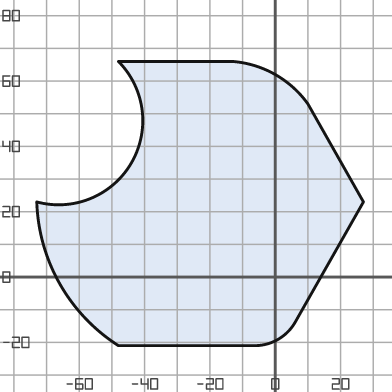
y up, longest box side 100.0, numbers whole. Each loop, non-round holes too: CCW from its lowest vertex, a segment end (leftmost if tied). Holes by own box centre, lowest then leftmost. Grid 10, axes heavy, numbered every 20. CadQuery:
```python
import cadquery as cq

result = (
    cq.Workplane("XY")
    .moveTo(-48.0, -21.0)
    .lineTo(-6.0, -21.0)
    .threePointArc((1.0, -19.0), (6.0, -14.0))
    .lineTo(27.0, 23.0)
    .lineTo(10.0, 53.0)
    .threePointArc((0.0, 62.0), (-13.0, 66.0))
    .lineTo(-48.0, 66.0)
    .threePointArc((-44.0, 35.0), (-73.0, 23.0))
    .threePointArc((-66.0, -2.0), (-48.0, -21.0))
    .close()
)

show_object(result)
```